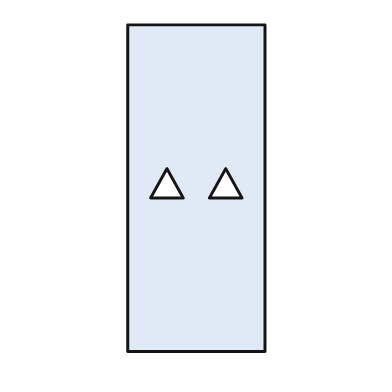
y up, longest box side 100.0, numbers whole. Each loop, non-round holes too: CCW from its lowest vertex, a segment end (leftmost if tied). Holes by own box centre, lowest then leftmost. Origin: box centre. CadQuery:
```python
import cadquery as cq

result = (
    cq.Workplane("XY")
    .moveTo(-21.0, -50.0)
    .lineTo(21.0, -50.0)
    .lineTo(21.0, 50.0)
    .lineTo(-21.0, 50.0)
    .close()
    .moveTo(-14.0, -3.0)
    .lineTo(-4.0, -3.0)
    .lineTo(-9.0, 6.0)
    .close()
    .moveTo(4.0, -3.0)
    .lineTo(14.0, -3.0)
    .lineTo(9.0, 6.0)
    .close()
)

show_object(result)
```